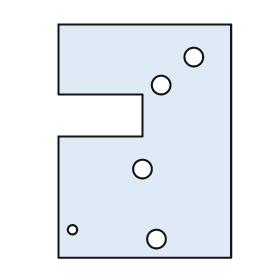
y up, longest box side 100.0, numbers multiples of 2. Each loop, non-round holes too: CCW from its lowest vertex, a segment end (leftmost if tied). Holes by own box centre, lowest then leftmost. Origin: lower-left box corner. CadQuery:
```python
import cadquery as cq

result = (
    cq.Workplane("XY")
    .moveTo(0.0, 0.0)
    .lineTo(74.0, 0.0)
    .lineTo(74.0, 100.0)
    .lineTo(0.0, 100.0)
    .lineTo(0.0, 70.0)
    .lineTo(36.0, 70.0)
    .lineTo(36.0, 52.0)
    .lineTo(0.0, 52.0)
    .close()
    .moveTo(42.0, 8.0)
    .circle(4.0)
    .moveTo(6.0, 12.0)
    .circle(2.0)
    .moveTo(36.0, 38.0)
    .circle(4.0)
    .moveTo(44.0, 74.0)
    .circle(4.0)
    .moveTo(58.0, 86.0)
    .circle(4.0)
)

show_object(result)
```